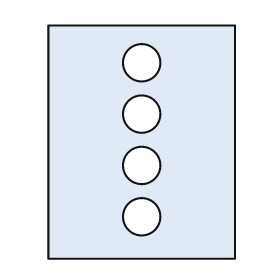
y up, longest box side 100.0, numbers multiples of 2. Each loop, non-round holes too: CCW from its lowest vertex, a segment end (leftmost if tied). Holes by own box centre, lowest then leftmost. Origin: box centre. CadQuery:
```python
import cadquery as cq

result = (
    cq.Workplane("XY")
    .moveTo(-40.0, -50.0)
    .lineTo(40.0, -50.0)
    .lineTo(40.0, 50.0)
    .lineTo(-40.0, 50.0)
    .close()
    .moveTo(0.0, -32.0)
    .circle(8.0)
    .moveTo(0.0, -10.0)
    .circle(8.0)
    .moveTo(0.0, 12.0)
    .circle(8.0)
    .moveTo(0.0, 34.0)
    .circle(8.0)
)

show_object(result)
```